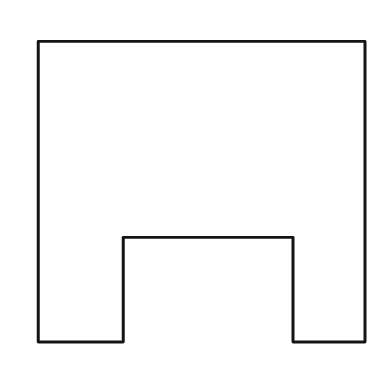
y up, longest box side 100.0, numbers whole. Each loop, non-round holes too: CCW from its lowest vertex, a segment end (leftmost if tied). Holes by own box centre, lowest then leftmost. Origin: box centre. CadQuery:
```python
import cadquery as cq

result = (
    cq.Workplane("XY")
    .moveTo(-50.0, -46.0)
    .lineTo(-24.0, -46.0)
    .lineTo(-24.0, -14.0)
    .lineTo(28.0, -14.0)
    .lineTo(28.0, -46.0)
    .lineTo(50.0, -46.0)
    .lineTo(50.0, 46.0)
    .lineTo(-50.0, 46.0)
    .close()
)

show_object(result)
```